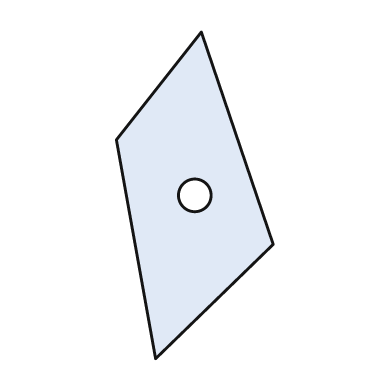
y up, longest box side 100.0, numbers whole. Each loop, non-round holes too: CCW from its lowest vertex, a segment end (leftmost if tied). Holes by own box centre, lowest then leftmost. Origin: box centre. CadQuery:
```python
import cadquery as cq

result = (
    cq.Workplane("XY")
    .moveTo(-12.0, -50.0)
    .lineTo(24.0, -15.0)
    .lineTo(2.0, 50.0)
    .lineTo(-24.0, 17.0)
    .close()
    .moveTo(0.0, 0.0)
    .circle(5.0)
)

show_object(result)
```